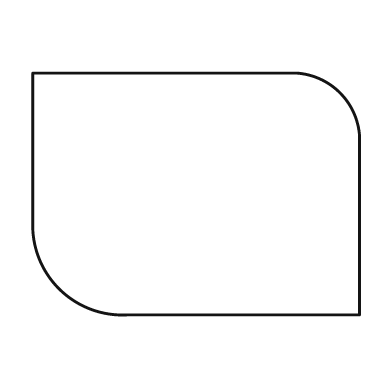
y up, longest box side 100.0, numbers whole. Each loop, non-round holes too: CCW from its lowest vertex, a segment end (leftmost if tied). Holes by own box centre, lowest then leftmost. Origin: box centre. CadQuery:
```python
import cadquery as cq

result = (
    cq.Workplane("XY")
    .moveTo(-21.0, -37.0)
    .lineTo(50.0, -37.0)
    .lineTo(50.0, 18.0)
    .threePointArc((44.0, 31.0), (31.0, 37.0))
    .lineTo(-50.0, 37.0)
    .lineTo(-50.0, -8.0)
    .threePointArc((-42.0, -29.0), (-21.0, -37.0))
    .close()
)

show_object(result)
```